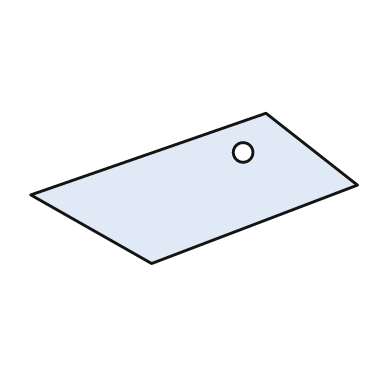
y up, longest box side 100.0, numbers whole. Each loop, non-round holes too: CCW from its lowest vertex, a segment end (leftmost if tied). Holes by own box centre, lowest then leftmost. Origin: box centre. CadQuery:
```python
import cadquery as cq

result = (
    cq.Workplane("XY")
    .moveTo(-13.0, -23.0)
    .lineTo(50.0, 1.0)
    .lineTo(22.0, 23.0)
    .lineTo(-50.0, -2.0)
    .close()
    .moveTo(15.0, 11.0)
    .circle(3.0)
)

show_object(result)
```